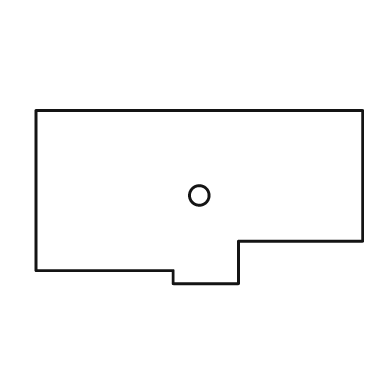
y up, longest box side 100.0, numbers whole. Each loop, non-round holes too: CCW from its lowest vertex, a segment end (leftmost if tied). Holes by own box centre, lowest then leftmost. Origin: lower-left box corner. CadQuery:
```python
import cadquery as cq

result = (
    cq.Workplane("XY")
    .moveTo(42.0, 0.0)
    .lineTo(62.0, 0.0)
    .lineTo(62.0, 13.0)
    .lineTo(100.0, 13.0)
    .lineTo(100.0, 53.0)
    .lineTo(0.0, 53.0)
    .lineTo(0.0, 4.0)
    .lineTo(42.0, 4.0)
    .close()
    .moveTo(50.0, 27.0)
    .circle(3.0)
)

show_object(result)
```